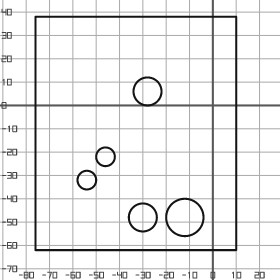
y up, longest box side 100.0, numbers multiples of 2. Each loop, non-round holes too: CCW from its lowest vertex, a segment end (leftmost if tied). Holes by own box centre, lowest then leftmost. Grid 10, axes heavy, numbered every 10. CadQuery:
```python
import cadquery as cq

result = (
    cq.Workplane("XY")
    .moveTo(-76.0, -62.0)
    .lineTo(10.0, -62.0)
    .lineTo(10.0, 38.0)
    .lineTo(-76.0, 38.0)
    .close()
    .moveTo(-30.0, -48.0)
    .circle(6.0)
    .moveTo(-12.0, -48.0)
    .circle(8.0)
    .moveTo(-54.0, -32.0)
    .circle(4.0)
    .moveTo(-46.0, -22.0)
    .circle(4.0)
    .moveTo(-28.0, 6.0)
    .circle(6.0)
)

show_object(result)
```